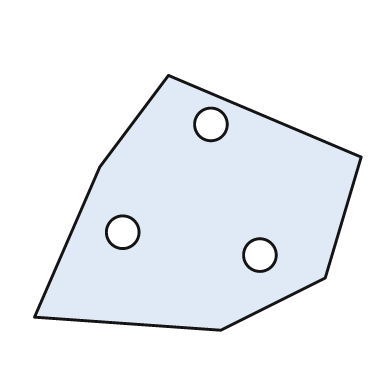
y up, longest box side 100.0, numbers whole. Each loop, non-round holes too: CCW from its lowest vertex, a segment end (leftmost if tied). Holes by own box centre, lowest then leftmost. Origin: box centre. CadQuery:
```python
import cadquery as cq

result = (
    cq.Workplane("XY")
    .moveTo(7.0, -39.0)
    .lineTo(39.0, -23.0)
    .lineTo(50.0, 14.0)
    .lineTo(-9.0, 39.0)
    .lineTo(-30.0, 11.0)
    .lineTo(-50.0, -35.0)
    .close()
    .moveTo(19.0, -16.0)
    .circle(5.0)
    .moveTo(-23.0, -9.0)
    .circle(5.0)
    .moveTo(4.0, 24.0)
    .circle(5.0)
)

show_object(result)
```